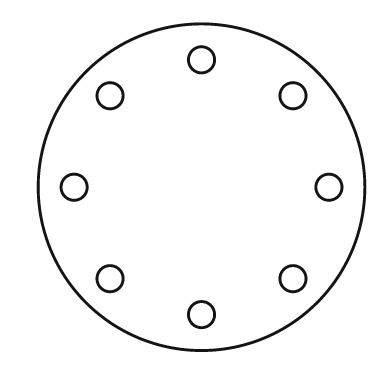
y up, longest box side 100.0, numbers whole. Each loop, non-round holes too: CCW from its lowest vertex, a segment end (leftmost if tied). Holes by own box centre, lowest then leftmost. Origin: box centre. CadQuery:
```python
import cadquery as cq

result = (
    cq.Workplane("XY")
    .moveTo(0.0, 0.0)
    .circle(50.0)
    .moveTo(0.0, -39.0)
    .circle(4.0)
    .moveTo(-28.0, -28.0)
    .circle(4.0)
    .moveTo(28.0, -28.0)
    .circle(4.0)
    .moveTo(-39.0, 0.0)
    .circle(4.0)
    .moveTo(39.0, 0.0)
    .circle(4.0)
    .moveTo(-28.0, 28.0)
    .circle(4.0)
    .moveTo(28.0, 28.0)
    .circle(4.0)
    .moveTo(0.0, 39.0)
    .circle(4.0)
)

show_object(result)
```